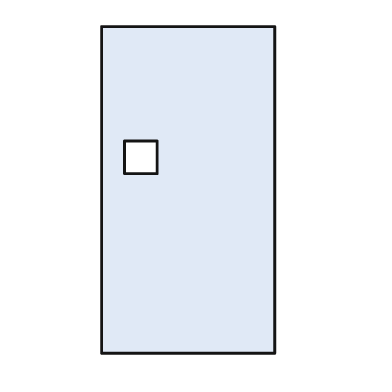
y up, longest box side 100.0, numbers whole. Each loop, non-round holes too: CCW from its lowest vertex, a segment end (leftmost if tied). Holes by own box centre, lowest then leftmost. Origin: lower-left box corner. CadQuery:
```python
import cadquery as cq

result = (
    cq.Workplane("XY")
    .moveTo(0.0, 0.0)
    .lineTo(53.0, 0.0)
    .lineTo(53.0, 100.0)
    .lineTo(0.0, 100.0)
    .close()
    .moveTo(7.0, 55.0)
    .lineTo(17.0, 55.0)
    .lineTo(17.0, 65.0)
    .lineTo(7.0, 65.0)
    .close()
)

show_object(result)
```